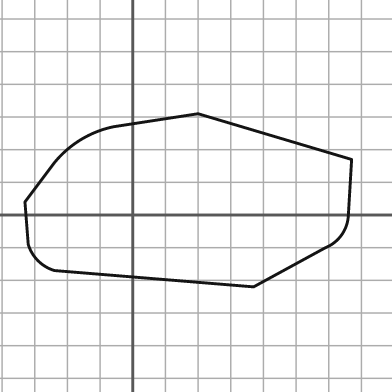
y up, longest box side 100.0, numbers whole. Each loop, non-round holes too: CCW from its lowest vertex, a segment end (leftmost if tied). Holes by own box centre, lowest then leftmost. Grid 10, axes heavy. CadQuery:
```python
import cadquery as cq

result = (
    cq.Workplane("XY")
    .moveTo(37.0, -22.0)
    .lineTo(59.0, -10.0)
    .threePointArc((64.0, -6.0), (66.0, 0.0))
    .lineTo(67.0, 17.0)
    .lineTo(20.0, 31.0)
    .lineTo(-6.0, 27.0)
    .threePointArc((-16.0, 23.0), (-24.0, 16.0))
    .lineTo(-33.0, 4.0)
    .lineTo(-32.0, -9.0)
    .threePointArc((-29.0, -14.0), (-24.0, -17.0))
    .close()
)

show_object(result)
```